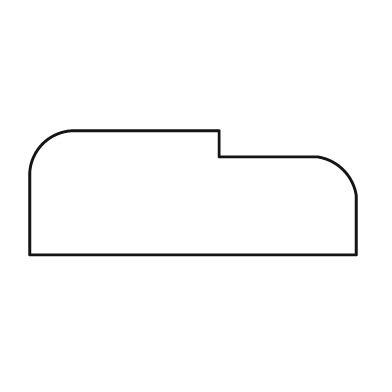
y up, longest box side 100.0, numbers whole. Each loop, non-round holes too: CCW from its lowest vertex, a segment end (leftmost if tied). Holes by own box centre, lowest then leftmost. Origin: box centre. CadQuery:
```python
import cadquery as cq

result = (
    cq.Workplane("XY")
    .moveTo(-50.0, -19.0)
    .lineTo(50.0, -19.0)
    .lineTo(50.0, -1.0)
    .threePointArc((46.0, 7.0), (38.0, 11.0))
    .lineTo(8.0, 11.0)
    .lineTo(8.0, 19.0)
    .lineTo(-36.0, 19.0)
    .threePointArc((-46.0, 15.0), (-50.0, 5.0))
    .close()
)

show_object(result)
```